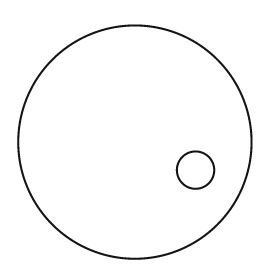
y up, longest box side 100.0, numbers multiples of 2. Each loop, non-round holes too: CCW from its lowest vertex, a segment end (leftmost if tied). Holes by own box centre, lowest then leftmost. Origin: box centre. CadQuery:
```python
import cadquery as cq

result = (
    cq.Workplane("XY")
    .moveTo(0.0, 0.0)
    .circle(50.0)
    .moveTo(26.0, -12.0)
    .circle(8.0)
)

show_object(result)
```